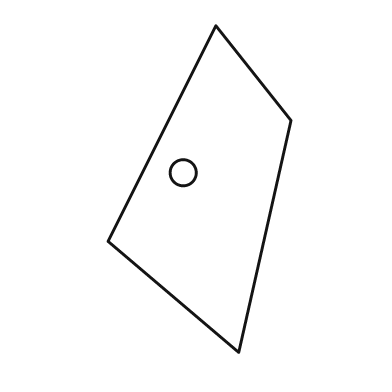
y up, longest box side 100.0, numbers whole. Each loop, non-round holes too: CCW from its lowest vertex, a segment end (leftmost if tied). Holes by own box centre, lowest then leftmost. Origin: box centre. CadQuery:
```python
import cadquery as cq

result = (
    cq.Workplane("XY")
    .moveTo(12.0, -50.0)
    .lineTo(28.0, 21.0)
    .lineTo(5.0, 50.0)
    .lineTo(-28.0, -16.0)
    .close()
    .moveTo(-5.0, 5.0)
    .circle(4.0)
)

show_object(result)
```